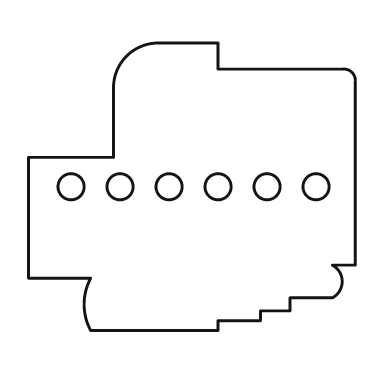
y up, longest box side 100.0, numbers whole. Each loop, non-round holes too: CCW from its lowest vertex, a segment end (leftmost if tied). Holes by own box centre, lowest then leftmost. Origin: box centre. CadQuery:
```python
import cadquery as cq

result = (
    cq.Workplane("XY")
    .moveTo(-31.0, -44.0)
    .lineTo(8.0, -44.0)
    .lineTo(8.0, -41.0)
    .lineTo(21.0, -41.0)
    .lineTo(21.0, -38.0)
    .lineTo(30.0, -38.0)
    .lineTo(30.0, -34.0)
    .lineTo(43.0, -34.0)
    .threePointArc((46.0, -29.0), (43.0, -24.0))
    .lineTo(50.0, -24.0)
    .lineTo(50.0, 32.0)
    .threePointArc((49.0, 35.0), (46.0, 36.0))
    .lineTo(8.0, 36.0)
    .lineTo(8.0, 44.0)
    .lineTo(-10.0, 44.0)
    .threePointArc((-20.0, 40.0), (-24.0, 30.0))
    .lineTo(-24.0, 9.0)
    .lineTo(-50.0, 9.0)
    .lineTo(-50.0, -28.0)
    .lineTo(-31.0, -28.0)
    .threePointArc((-33.0, -36.0), (-31.0, -44.0))
    .close()
    .moveTo(-37.0, 0.0)
    .circle(4.0)
    .moveTo(-22.0, 0.0)
    .circle(4.0)
    .moveTo(-7.0, 0.0)
    .circle(4.0)
    .moveTo(8.0, 0.0)
    .circle(4.0)
    .moveTo(23.0, 0.0)
    .circle(4.0)
    .moveTo(38.0, 0.0)
    .circle(4.0)
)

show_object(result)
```